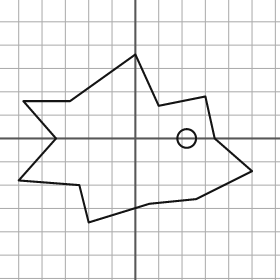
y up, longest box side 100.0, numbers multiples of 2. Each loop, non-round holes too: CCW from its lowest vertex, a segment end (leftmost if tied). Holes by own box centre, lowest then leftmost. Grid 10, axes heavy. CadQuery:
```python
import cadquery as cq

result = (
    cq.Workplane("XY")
    .moveTo(-20.0, -36.0)
    .lineTo(6.0, -28.0)
    .lineTo(26.0, -26.0)
    .lineTo(50.0, -14.0)
    .lineTo(34.0, 0.0)
    .lineTo(30.0, 18.0)
    .lineTo(10.0, 14.0)
    .lineTo(0.0, 36.0)
    .lineTo(-28.0, 16.0)
    .lineTo(-48.0, 16.0)
    .lineTo(-34.0, 0.0)
    .lineTo(-50.0, -18.0)
    .lineTo(-24.0, -20.0)
    .close()
    .moveTo(22.0, 0.0)
    .circle(4.0)
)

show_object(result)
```